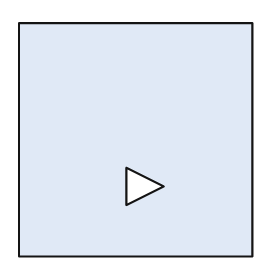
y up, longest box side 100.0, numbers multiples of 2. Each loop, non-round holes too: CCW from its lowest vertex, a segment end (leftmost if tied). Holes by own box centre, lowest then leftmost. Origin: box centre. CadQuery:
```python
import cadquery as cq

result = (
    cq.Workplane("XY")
    .moveTo(-50.0, -50.0)
    .lineTo(50.0, -50.0)
    .lineTo(50.0, 50.0)
    .lineTo(-50.0, 50.0)
    .close()
    .moveTo(-4.0, -28.0)
    .lineTo(12.0, -20.0)
    .lineTo(-4.0, -12.0)
    .close()
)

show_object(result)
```